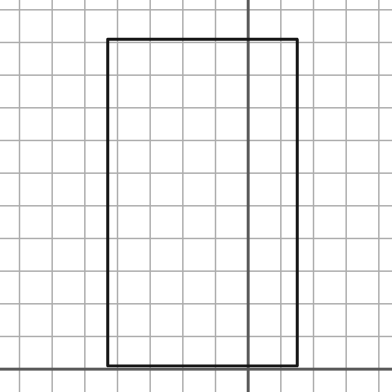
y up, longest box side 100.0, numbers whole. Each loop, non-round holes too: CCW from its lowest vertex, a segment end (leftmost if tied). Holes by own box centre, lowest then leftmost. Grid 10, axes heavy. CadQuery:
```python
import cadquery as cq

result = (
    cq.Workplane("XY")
    .moveTo(-43.0, 1.0)
    .lineTo(15.0, 1.0)
    .lineTo(15.0, 101.0)
    .lineTo(-43.0, 101.0)
    .close()
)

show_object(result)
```